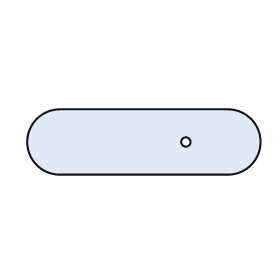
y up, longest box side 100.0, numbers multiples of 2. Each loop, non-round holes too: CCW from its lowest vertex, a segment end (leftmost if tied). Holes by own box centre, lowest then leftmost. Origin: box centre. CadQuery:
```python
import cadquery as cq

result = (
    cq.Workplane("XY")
    .moveTo(-36.0, -14.0)
    .lineTo(36.0, -14.0)
    .threePointArc((50.0, 0.0), (36.0, 14.0))
    .lineTo(-36.0, 14.0)
    .threePointArc((-50.0, 0.0), (-36.0, -14.0))
    .close()
    .moveTo(18.0, 0.0)
    .circle(2.0)
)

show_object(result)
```